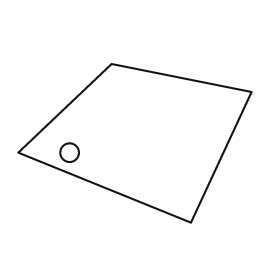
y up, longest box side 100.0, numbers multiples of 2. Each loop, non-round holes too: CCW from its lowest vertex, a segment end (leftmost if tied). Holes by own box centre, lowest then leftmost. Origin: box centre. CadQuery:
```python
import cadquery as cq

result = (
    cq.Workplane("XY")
    .moveTo(24.0, -34.0)
    .lineTo(50.0, 22.0)
    .lineTo(-10.0, 34.0)
    .lineTo(-50.0, -4.0)
    .close()
    .moveTo(-28.0, -4.0)
    .circle(4.0)
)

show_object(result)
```